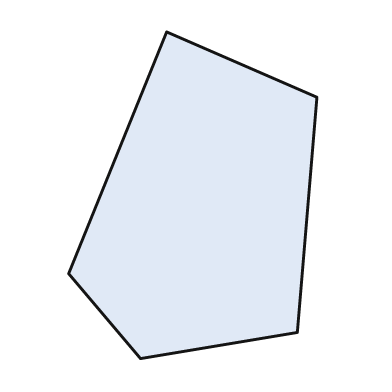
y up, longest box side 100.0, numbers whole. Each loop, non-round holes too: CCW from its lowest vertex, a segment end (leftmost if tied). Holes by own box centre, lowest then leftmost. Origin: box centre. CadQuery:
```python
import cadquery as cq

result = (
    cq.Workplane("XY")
    .moveTo(-16.0, -50.0)
    .lineTo(32.0, -42.0)
    .lineTo(38.0, 30.0)
    .lineTo(-8.0, 50.0)
    .lineTo(-38.0, -24.0)
    .close()
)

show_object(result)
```